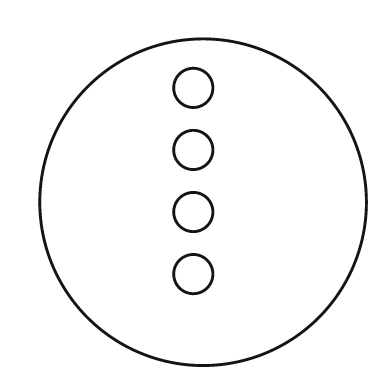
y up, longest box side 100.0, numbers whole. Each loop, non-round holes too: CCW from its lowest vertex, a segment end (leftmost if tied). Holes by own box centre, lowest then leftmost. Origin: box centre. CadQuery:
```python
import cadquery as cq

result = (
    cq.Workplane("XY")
    .moveTo(0.0, 0.0)
    .circle(50.0)
    .moveTo(-3.0, -22.0)
    .circle(6.0)
    .moveTo(-3.0, -3.0)
    .circle(6.0)
    .moveTo(-3.0, 16.0)
    .circle(6.0)
    .moveTo(-3.0, 35.0)
    .circle(6.0)
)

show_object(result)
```